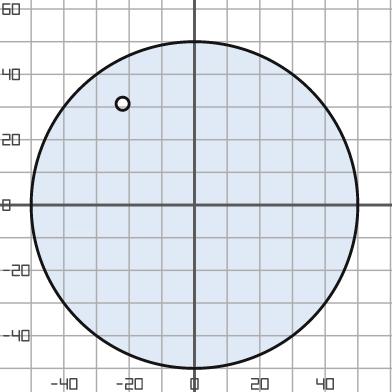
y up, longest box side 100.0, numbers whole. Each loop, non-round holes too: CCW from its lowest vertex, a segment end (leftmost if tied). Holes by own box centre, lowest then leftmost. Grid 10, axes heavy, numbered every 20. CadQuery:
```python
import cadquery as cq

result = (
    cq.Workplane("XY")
    .moveTo(0.0, 0.0)
    .circle(50.0)
    .moveTo(-22.0, 31.0)
    .circle(2.0)
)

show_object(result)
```